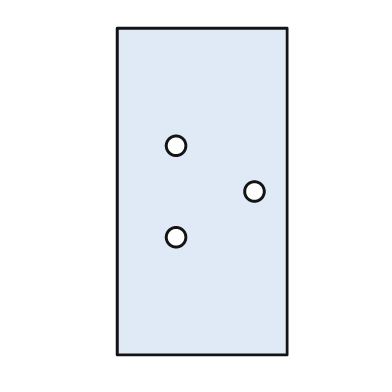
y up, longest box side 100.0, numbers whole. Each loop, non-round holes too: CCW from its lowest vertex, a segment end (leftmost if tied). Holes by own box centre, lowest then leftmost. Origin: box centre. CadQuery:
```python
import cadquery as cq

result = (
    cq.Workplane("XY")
    .moveTo(-26.0, -50.0)
    .lineTo(26.0, -50.0)
    .lineTo(26.0, 50.0)
    .lineTo(-26.0, 50.0)
    .close()
    .moveTo(-8.0, -14.0)
    .circle(3.0)
    .moveTo(16.0, 0.0)
    .circle(3.0)
    .moveTo(-8.0, 14.0)
    .circle(3.0)
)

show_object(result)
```